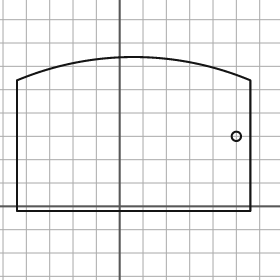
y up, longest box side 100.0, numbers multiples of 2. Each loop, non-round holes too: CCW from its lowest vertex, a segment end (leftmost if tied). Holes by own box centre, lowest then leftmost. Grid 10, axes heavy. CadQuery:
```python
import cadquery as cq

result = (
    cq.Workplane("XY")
    .moveTo(-44.0, -2.0)
    .lineTo(56.0, -2.0)
    .lineTo(56.0, 54.0)
    .threePointArc((6.0, 64.0), (-44.0, 54.0))
    .close()
    .moveTo(50.0, 30.0)
    .circle(2.0)
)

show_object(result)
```